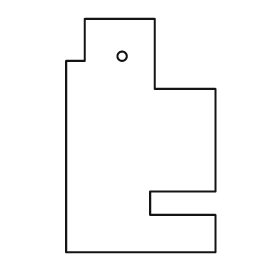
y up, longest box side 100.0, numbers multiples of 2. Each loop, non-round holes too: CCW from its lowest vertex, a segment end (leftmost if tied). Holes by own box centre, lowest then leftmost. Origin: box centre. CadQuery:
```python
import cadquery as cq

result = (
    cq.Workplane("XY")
    .moveTo(-32.0, -50.0)
    .lineTo(32.0, -50.0)
    .lineTo(32.0, -34.0)
    .lineTo(4.0, -34.0)
    .lineTo(4.0, -24.0)
    .lineTo(32.0, -24.0)
    .lineTo(32.0, 20.0)
    .lineTo(6.0, 20.0)
    .lineTo(6.0, 50.0)
    .lineTo(-24.0, 50.0)
    .lineTo(-24.0, 32.0)
    .lineTo(-32.0, 32.0)
    .close()
    .moveTo(-8.0, 34.0)
    .circle(2.0)
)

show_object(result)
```